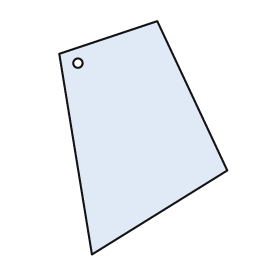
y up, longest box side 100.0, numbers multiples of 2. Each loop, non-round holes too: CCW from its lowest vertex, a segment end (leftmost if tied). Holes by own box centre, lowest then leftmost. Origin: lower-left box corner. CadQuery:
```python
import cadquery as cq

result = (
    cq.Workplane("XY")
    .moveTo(14.0, 0.0)
    .lineTo(72.0, 36.0)
    .lineTo(42.0, 100.0)
    .lineTo(0.0, 86.0)
    .close()
    .moveTo(8.0, 82.0)
    .circle(2.0)
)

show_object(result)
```